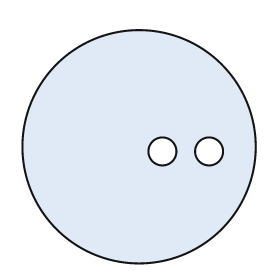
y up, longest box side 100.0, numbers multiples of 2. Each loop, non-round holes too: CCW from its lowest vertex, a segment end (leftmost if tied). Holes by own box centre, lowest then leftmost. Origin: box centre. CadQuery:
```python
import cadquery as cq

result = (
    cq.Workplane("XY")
    .moveTo(0.0, 0.0)
    .circle(50.0)
    .moveTo(10.0, -2.0)
    .circle(6.0)
    .moveTo(30.0, -2.0)
    .circle(6.0)
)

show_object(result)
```